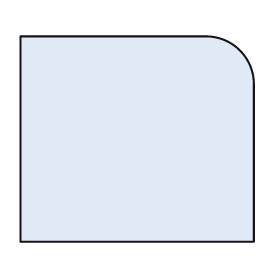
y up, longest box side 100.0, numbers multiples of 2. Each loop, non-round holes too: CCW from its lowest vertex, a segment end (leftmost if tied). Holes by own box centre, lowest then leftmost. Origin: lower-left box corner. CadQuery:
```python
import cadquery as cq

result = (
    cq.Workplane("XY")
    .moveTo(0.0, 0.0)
    .lineTo(100.0, 0.0)
    .lineTo(100.0, 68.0)
    .threePointArc((94.0, 82.0), (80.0, 88.0))
    .lineTo(0.0, 88.0)
    .close()
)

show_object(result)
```